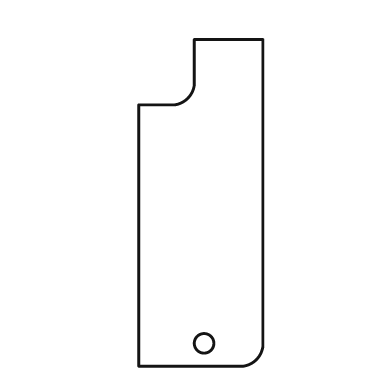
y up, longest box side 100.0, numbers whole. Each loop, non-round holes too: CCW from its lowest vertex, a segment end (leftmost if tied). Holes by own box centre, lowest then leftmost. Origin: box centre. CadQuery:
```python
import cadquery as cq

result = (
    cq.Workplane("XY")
    .moveTo(-19.0, -50.0)
    .lineTo(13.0, -50.0)
    .threePointArc((17.0, -48.0), (19.0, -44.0))
    .lineTo(19.0, 50.0)
    .lineTo(-2.0, 50.0)
    .lineTo(-2.0, 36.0)
    .threePointArc((-4.0, 32.0), (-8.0, 30.0))
    .lineTo(-19.0, 30.0)
    .close()
    .moveTo(1.0, -43.0)
    .circle(3.0)
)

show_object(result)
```